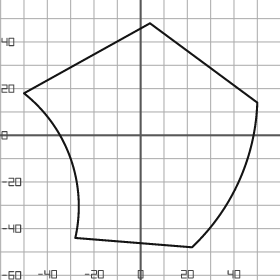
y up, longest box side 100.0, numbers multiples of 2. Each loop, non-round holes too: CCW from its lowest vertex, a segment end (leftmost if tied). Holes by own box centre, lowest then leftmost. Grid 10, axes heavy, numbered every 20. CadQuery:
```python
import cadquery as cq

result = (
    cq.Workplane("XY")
    .moveTo(22.0, -48.0)
    .threePointArc((42.0, -20.0), (50.0, 14.0))
    .lineTo(4.0, 48.0)
    .lineTo(-50.0, 18.0)
    .threePointArc((-30.0, -10.0), (-28.0, -44.0))
    .close()
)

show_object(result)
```